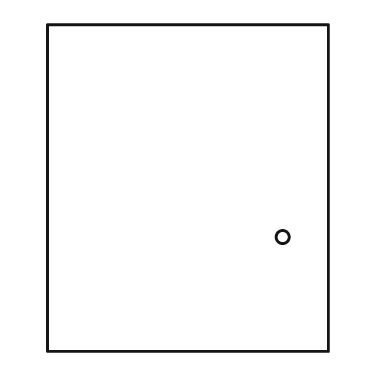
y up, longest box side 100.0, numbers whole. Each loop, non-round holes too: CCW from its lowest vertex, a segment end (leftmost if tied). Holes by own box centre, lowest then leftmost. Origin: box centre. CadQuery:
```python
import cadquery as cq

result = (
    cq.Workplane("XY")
    .moveTo(-43.0, -50.0)
    .lineTo(43.0, -50.0)
    .lineTo(43.0, 50.0)
    .lineTo(-43.0, 50.0)
    .close()
    .moveTo(29.0, -15.0)
    .circle(2.0)
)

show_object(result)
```